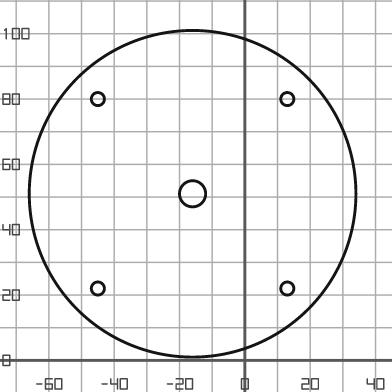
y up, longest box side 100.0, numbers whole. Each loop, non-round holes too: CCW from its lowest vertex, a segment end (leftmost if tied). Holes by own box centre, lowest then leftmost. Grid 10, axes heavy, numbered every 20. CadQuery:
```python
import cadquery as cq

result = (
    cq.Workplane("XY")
    .moveTo(-16.0, 51.0)
    .circle(50.0)
    .moveTo(-45.0, 22.0)
    .circle(2.0)
    .moveTo(13.0, 22.0)
    .circle(2.0)
    .moveTo(-16.0, 51.0)
    .circle(4.0)
    .moveTo(-45.0, 80.0)
    .circle(2.0)
    .moveTo(13.0, 80.0)
    .circle(2.0)
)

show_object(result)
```